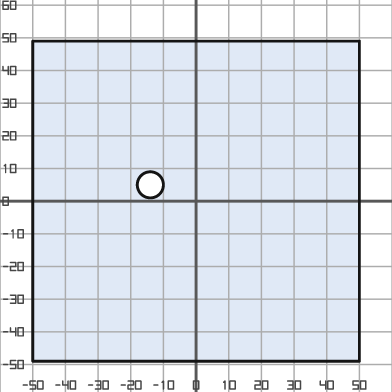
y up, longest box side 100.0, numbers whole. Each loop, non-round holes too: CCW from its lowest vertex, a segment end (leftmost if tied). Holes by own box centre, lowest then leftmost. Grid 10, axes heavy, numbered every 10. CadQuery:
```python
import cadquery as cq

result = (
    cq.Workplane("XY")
    .moveTo(-50.0, -49.0)
    .lineTo(50.0, -49.0)
    .lineTo(50.0, 49.0)
    .lineTo(-50.0, 49.0)
    .close()
    .moveTo(-14.0, 5.0)
    .circle(4.0)
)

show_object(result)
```